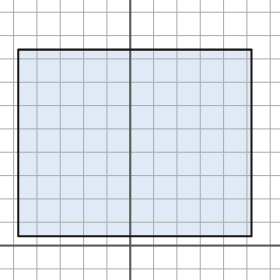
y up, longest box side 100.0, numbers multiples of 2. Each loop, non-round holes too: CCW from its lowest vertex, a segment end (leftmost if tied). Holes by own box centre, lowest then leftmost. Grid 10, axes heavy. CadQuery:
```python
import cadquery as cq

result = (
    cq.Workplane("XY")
    .moveTo(-48.0, 4.0)
    .lineTo(52.0, 4.0)
    .lineTo(52.0, 84.0)
    .lineTo(-48.0, 84.0)
    .close()
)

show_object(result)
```